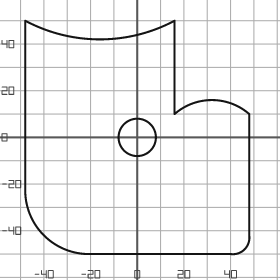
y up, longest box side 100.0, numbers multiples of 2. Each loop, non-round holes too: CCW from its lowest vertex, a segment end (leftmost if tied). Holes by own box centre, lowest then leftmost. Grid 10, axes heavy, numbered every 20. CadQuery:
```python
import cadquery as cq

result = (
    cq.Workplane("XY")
    .moveTo(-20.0, -50.0)
    .lineTo(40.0, -50.0)
    .threePointArc((46.0, -48.0), (48.0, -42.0))
    .lineTo(48.0, 10.0)
    .threePointArc((32.0, 16.0), (16.0, 10.0))
    .lineTo(16.0, 50.0)
    .threePointArc((-16.0, 42.0), (-48.0, 50.0))
    .lineTo(-48.0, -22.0)
    .threePointArc((-40.0, -42.0), (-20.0, -50.0))
    .close()
    .moveTo(0.0, 0.0)
    .circle(8.0)
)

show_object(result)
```